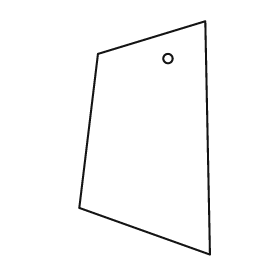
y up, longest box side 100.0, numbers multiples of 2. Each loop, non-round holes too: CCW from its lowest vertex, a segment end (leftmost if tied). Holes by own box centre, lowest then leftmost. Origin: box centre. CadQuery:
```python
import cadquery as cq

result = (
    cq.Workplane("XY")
    .moveTo(28.0, -50.0)
    .lineTo(26.0, 50.0)
    .lineTo(-20.0, 36.0)
    .lineTo(-28.0, -30.0)
    .close()
    .moveTo(10.0, 34.0)
    .circle(2.0)
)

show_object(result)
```